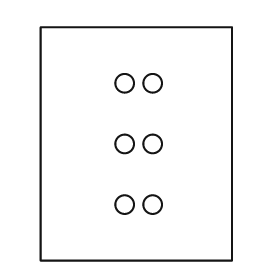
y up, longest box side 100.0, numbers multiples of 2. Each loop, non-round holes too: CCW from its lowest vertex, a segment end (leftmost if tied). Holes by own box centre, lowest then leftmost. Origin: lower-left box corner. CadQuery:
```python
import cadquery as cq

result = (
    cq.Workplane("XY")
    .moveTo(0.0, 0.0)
    .lineTo(82.0, 0.0)
    .lineTo(82.0, 100.0)
    .lineTo(0.0, 100.0)
    .close()
    .moveTo(36.0, 24.0)
    .circle(4.0)
    .moveTo(48.0, 24.0)
    .circle(4.0)
    .moveTo(36.0, 50.0)
    .circle(4.0)
    .moveTo(48.0, 50.0)
    .circle(4.0)
    .moveTo(36.0, 76.0)
    .circle(4.0)
    .moveTo(48.0, 76.0)
    .circle(4.0)
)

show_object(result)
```